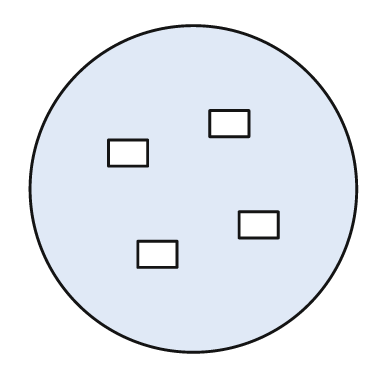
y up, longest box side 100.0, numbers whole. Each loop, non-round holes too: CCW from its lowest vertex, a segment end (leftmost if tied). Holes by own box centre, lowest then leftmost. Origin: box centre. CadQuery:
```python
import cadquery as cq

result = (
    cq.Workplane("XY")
    .moveTo(0.0, 0.0)
    .circle(50.0)
    .moveTo(-17.0, -24.0)
    .lineTo(-5.0, -24.0)
    .lineTo(-5.0, -16.0)
    .lineTo(-17.0, -16.0)
    .close()
    .moveTo(14.0, -15.0)
    .lineTo(26.0, -15.0)
    .lineTo(26.0, -7.0)
    .lineTo(14.0, -7.0)
    .close()
    .moveTo(-26.0, 7.0)
    .lineTo(-14.0, 7.0)
    .lineTo(-14.0, 15.0)
    .lineTo(-26.0, 15.0)
    .close()
    .moveTo(5.0, 16.0)
    .lineTo(17.0, 16.0)
    .lineTo(17.0, 24.0)
    .lineTo(5.0, 24.0)
    .close()
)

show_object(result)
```